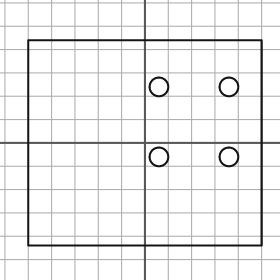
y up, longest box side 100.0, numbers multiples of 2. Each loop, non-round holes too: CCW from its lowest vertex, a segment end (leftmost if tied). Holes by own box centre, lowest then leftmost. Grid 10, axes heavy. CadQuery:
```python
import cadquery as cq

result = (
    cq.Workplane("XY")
    .moveTo(-50.0, -44.0)
    .lineTo(50.0, -44.0)
    .lineTo(50.0, 44.0)
    .lineTo(-50.0, 44.0)
    .close()
    .moveTo(6.0, -6.0)
    .circle(4.0)
    .moveTo(36.0, -6.0)
    .circle(4.0)
    .moveTo(6.0, 24.0)
    .circle(4.0)
    .moveTo(36.0, 24.0)
    .circle(4.0)
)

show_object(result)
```